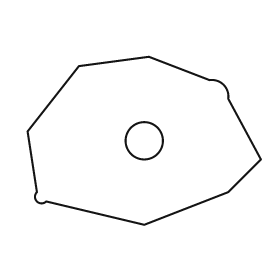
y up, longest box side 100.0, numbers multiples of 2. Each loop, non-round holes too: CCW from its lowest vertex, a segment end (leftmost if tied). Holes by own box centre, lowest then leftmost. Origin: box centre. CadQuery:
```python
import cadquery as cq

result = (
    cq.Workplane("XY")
    .moveTo(0.0, -36.0)
    .lineTo(36.0, -22.0)
    .lineTo(50.0, -8.0)
    .lineTo(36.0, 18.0)
    .threePointArc((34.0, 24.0), (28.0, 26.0))
    .lineTo(2.0, 36.0)
    .lineTo(-28.0, 32.0)
    .lineTo(-50.0, 4.0)
    .lineTo(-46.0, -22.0)
    .threePointArc((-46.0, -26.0), (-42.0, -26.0))
    .close()
    .moveTo(0.0, 0.0)
    .circle(8.0)
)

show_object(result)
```